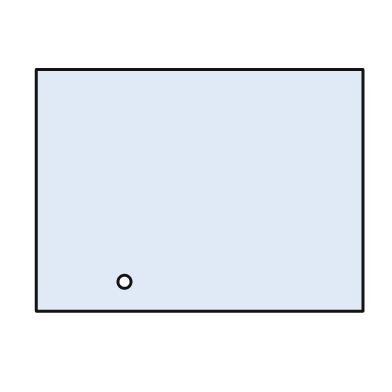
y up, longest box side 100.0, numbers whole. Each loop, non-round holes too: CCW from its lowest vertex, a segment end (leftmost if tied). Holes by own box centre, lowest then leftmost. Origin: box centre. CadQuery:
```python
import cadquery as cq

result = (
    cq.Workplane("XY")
    .moveTo(-50.0, -37.0)
    .lineTo(50.0, -37.0)
    .lineTo(50.0, 37.0)
    .lineTo(-50.0, 37.0)
    .close()
    .moveTo(-23.0, -28.0)
    .circle(2.0)
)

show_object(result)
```